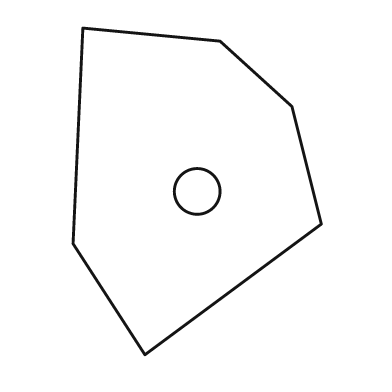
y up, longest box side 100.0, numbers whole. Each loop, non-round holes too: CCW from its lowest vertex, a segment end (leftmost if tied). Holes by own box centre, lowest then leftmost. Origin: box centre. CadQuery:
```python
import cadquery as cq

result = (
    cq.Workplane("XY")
    .moveTo(-16.0, -50.0)
    .lineTo(38.0, -10.0)
    .lineTo(29.0, 26.0)
    .lineTo(7.0, 46.0)
    .lineTo(-35.0, 50.0)
    .lineTo(-38.0, -16.0)
    .close()
    .moveTo(0.0, 0.0)
    .circle(7.0)
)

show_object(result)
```